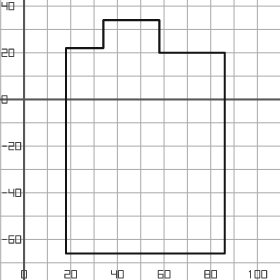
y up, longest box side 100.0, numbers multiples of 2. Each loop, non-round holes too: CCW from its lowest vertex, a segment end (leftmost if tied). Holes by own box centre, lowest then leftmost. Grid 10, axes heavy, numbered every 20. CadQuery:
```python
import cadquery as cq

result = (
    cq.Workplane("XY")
    .moveTo(18.0, -66.0)
    .lineTo(86.0, -66.0)
    .lineTo(86.0, 20.0)
    .lineTo(58.0, 20.0)
    .lineTo(58.0, 34.0)
    .lineTo(34.0, 34.0)
    .lineTo(34.0, 22.0)
    .lineTo(18.0, 22.0)
    .close()
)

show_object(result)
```